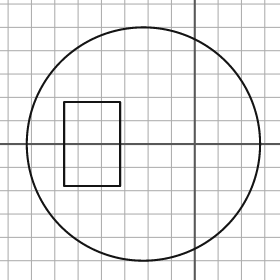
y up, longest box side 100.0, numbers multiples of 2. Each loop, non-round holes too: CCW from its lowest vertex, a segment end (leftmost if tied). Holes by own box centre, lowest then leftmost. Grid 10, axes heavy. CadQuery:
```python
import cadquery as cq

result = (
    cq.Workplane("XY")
    .moveTo(-22.0, 0.0)
    .circle(50.0)
    .moveTo(-56.0, -18.0)
    .lineTo(-32.0, -18.0)
    .lineTo(-32.0, 18.0)
    .lineTo(-56.0, 18.0)
    .close()
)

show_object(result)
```